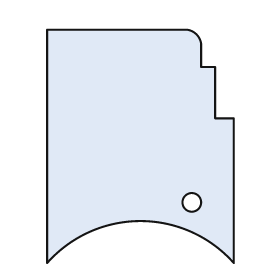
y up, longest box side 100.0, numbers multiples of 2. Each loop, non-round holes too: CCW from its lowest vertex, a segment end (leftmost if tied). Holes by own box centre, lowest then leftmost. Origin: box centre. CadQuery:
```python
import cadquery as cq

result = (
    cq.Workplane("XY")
    .moveTo(-40.0, -50.0)
    .threePointArc((0.0, -32.0), (40.0, -50.0))
    .lineTo(40.0, 12.0)
    .lineTo(32.0, 12.0)
    .lineTo(32.0, 34.0)
    .lineTo(26.0, 34.0)
    .lineTo(26.0, 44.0)
    .threePointArc((24.0, 48.0), (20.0, 50.0))
    .lineTo(-40.0, 50.0)
    .close()
    .moveTo(22.0, -24.0)
    .circle(4.0)
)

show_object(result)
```